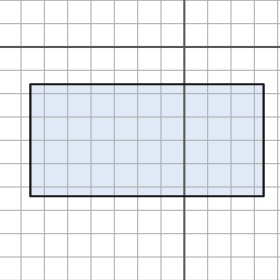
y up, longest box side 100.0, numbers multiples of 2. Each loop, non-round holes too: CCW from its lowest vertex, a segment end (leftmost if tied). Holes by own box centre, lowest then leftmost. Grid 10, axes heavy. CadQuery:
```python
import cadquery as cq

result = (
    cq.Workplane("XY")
    .moveTo(-66.0, -64.0)
    .lineTo(34.0, -64.0)
    .lineTo(34.0, -16.0)
    .lineTo(-66.0, -16.0)
    .close()
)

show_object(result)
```